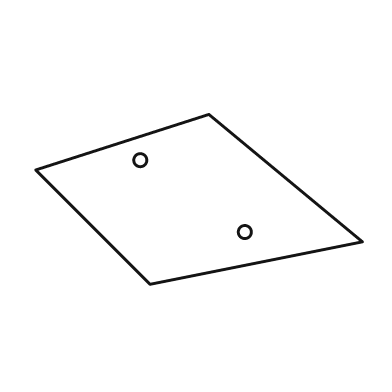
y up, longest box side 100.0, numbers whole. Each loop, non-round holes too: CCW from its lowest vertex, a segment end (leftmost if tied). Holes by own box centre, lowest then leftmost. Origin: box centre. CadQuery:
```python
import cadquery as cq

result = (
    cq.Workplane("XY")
    .moveTo(-15.0, -26.0)
    .lineTo(50.0, -13.0)
    .lineTo(3.0, 26.0)
    .lineTo(-50.0, 9.0)
    .close()
    .moveTo(14.0, -10.0)
    .circle(2.0)
    .moveTo(-18.0, 12.0)
    .circle(2.0)
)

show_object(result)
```